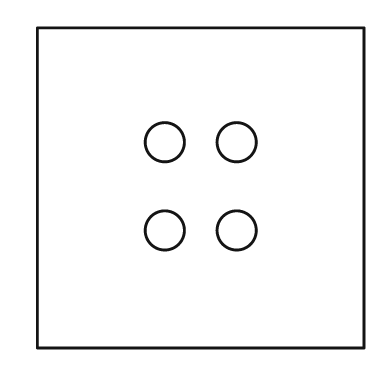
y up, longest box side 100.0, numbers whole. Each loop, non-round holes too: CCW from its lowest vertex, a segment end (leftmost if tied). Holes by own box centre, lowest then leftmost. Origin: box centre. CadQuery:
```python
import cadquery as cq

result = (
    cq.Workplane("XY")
    .moveTo(-50.0, -49.0)
    .lineTo(50.0, -49.0)
    .lineTo(50.0, 49.0)
    .lineTo(-50.0, 49.0)
    .close()
    .moveTo(-11.0, -13.0)
    .circle(6.0)
    .moveTo(11.0, -13.0)
    .circle(6.0)
    .moveTo(-11.0, 14.0)
    .circle(6.0)
    .moveTo(11.0, 14.0)
    .circle(6.0)
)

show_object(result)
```